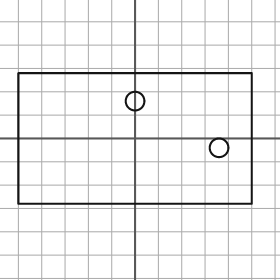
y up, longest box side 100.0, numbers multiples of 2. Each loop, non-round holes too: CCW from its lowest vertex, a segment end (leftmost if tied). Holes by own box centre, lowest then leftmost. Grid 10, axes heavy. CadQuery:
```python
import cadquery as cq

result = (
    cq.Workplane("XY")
    .moveTo(-50.0, -28.0)
    .lineTo(50.0, -28.0)
    .lineTo(50.0, 28.0)
    .lineTo(-50.0, 28.0)
    .close()
    .moveTo(36.0, -4.0)
    .circle(4.0)
    .moveTo(0.0, 16.0)
    .circle(4.0)
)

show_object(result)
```